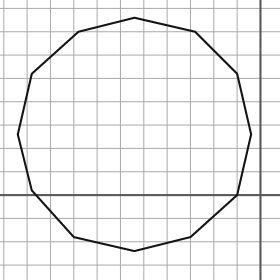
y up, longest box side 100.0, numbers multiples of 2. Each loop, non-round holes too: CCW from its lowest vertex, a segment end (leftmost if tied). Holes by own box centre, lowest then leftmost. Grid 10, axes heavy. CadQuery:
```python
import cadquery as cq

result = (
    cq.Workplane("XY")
    .moveTo(-54.0, -24.0)
    .lineTo(-30.0, -18.0)
    .lineTo(-10.0, 0.0)
    .lineTo(-4.0, 26.0)
    .lineTo(-10.0, 52.0)
    .lineTo(-28.0, 70.0)
    .lineTo(-54.0, 76.0)
    .lineTo(-78.0, 70.0)
    .lineTo(-98.0, 52.0)
    .lineTo(-104.0, 26.0)
    .lineTo(-98.0, 2.0)
    .lineTo(-80.0, -18.0)
    .close()
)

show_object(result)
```